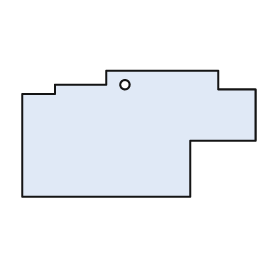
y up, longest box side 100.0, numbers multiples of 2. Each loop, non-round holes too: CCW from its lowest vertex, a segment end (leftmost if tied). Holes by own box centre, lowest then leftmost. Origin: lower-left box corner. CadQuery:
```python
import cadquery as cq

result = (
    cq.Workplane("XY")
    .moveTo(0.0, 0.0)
    .lineTo(72.0, 0.0)
    .lineTo(72.0, 24.0)
    .lineTo(100.0, 24.0)
    .lineTo(100.0, 46.0)
    .lineTo(84.0, 46.0)
    .lineTo(84.0, 54.0)
    .lineTo(36.0, 54.0)
    .lineTo(36.0, 48.0)
    .lineTo(14.0, 48.0)
    .lineTo(14.0, 44.0)
    .lineTo(0.0, 44.0)
    .close()
    .moveTo(44.0, 48.0)
    .circle(2.0)
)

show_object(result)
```